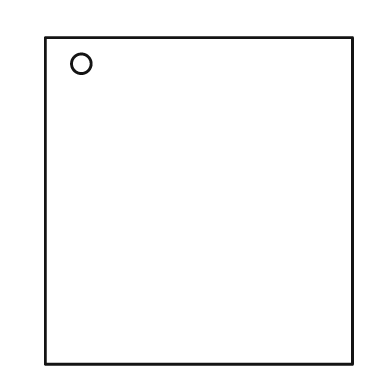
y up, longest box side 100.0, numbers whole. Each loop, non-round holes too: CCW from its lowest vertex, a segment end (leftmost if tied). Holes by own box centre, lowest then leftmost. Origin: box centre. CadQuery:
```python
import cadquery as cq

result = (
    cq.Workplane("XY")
    .moveTo(-47.0, -50.0)
    .lineTo(47.0, -50.0)
    .lineTo(47.0, 50.0)
    .lineTo(-47.0, 50.0)
    .close()
    .moveTo(-36.0, 42.0)
    .circle(3.0)
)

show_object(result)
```